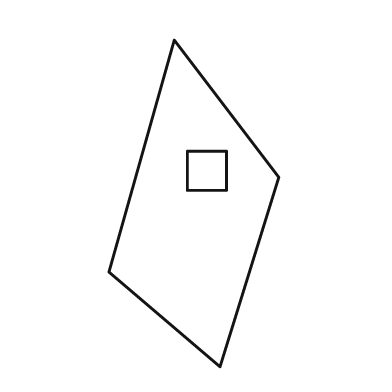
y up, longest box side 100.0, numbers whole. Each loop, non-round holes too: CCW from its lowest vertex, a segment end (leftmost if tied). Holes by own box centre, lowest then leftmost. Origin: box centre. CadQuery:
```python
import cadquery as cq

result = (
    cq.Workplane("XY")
    .moveTo(8.0, -50.0)
    .lineTo(26.0, 8.0)
    .lineTo(-6.0, 50.0)
    .lineTo(-26.0, -21.0)
    .close()
    .moveTo(-2.0, 4.0)
    .lineTo(10.0, 4.0)
    .lineTo(10.0, 16.0)
    .lineTo(-2.0, 16.0)
    .close()
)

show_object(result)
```